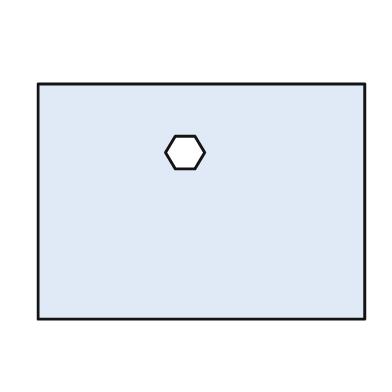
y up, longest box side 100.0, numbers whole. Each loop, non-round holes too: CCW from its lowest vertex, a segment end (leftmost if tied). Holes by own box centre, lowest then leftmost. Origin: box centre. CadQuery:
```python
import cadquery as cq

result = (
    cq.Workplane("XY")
    .moveTo(-50.0, -36.0)
    .lineTo(50.0, -36.0)
    .lineTo(50.0, 36.0)
    .lineTo(-50.0, 36.0)
    .close()
    .moveTo(-8.0, 10.0)
    .lineTo(-2.0, 10.0)
    .lineTo(1.0, 15.0)
    .lineTo(-2.0, 20.0)
    .lineTo(-8.0, 20.0)
    .lineTo(-11.0, 15.0)
    .close()
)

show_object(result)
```